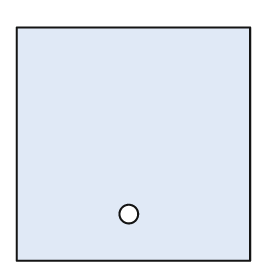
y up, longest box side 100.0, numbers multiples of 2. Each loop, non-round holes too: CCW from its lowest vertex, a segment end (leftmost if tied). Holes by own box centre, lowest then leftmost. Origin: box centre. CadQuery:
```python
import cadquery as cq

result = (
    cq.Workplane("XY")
    .moveTo(-50.0, -50.0)
    .lineTo(50.0, -50.0)
    .lineTo(50.0, 50.0)
    .lineTo(-50.0, 50.0)
    .close()
    .moveTo(-2.0, -30.0)
    .circle(4.0)
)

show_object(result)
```